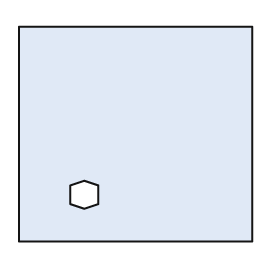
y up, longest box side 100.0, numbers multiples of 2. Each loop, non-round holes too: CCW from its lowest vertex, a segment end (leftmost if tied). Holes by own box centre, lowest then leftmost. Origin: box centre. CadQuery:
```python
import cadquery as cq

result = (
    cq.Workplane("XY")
    .moveTo(-50.0, -46.0)
    .lineTo(50.0, -46.0)
    .lineTo(50.0, 46.0)
    .lineTo(-50.0, 46.0)
    .close()
    .moveTo(-22.0, -32.0)
    .lineTo(-16.0, -30.0)
    .lineTo(-16.0, -22.0)
    .lineTo(-22.0, -20.0)
    .lineTo(-28.0, -22.0)
    .lineTo(-28.0, -30.0)
    .close()
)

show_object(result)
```